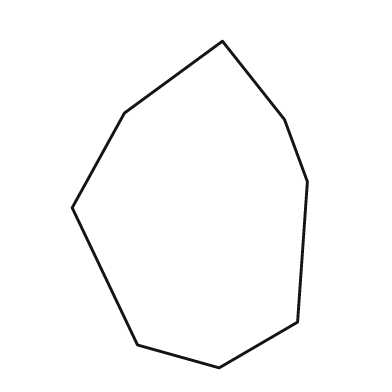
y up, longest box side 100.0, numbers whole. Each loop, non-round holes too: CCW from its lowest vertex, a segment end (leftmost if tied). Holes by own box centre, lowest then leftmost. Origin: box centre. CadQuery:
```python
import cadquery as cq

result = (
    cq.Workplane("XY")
    .moveTo(9.0, -50.0)
    .lineTo(33.0, -36.0)
    .lineTo(36.0, 7.0)
    .lineTo(29.0, 26.0)
    .lineTo(10.0, 50.0)
    .lineTo(-20.0, 28.0)
    .lineTo(-36.0, -1.0)
    .lineTo(-16.0, -43.0)
    .close()
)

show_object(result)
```